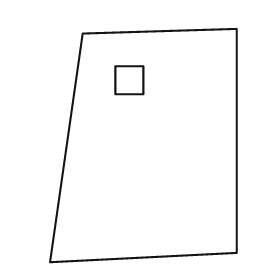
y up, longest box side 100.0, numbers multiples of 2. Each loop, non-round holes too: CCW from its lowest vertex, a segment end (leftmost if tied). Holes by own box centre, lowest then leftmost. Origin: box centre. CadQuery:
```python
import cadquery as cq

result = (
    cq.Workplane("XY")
    .moveTo(-40.0, -50.0)
    .lineTo(40.0, -46.0)
    .lineTo(40.0, 50.0)
    .lineTo(-26.0, 48.0)
    .close()
    .moveTo(-12.0, 22.0)
    .lineTo(0.0, 22.0)
    .lineTo(0.0, 34.0)
    .lineTo(-12.0, 34.0)
    .close()
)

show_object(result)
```